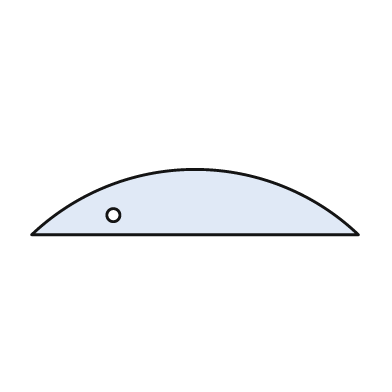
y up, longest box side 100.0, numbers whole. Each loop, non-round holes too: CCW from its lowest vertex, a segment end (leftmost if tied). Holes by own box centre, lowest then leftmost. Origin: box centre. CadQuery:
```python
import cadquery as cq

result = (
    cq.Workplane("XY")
    .moveTo(-50.0, -10.0)
    .lineTo(50.0, -10.0)
    .threePointArc((0.0, 10.0), (-50.0, -10.0))
    .close()
    .moveTo(-25.0, -4.0)
    .circle(2.0)
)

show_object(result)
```